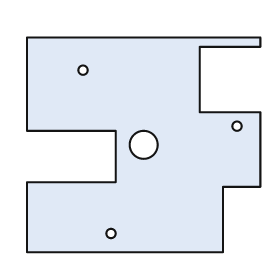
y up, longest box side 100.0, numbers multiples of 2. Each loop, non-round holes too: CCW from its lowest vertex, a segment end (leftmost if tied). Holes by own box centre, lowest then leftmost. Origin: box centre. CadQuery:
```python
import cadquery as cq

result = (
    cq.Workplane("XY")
    .moveTo(-50.0, -46.0)
    .lineTo(34.0, -46.0)
    .lineTo(34.0, -18.0)
    .lineTo(50.0, -18.0)
    .lineTo(50.0, 14.0)
    .lineTo(24.0, 14.0)
    .lineTo(24.0, 42.0)
    .lineTo(50.0, 42.0)
    .lineTo(50.0, 46.0)
    .lineTo(-50.0, 46.0)
    .lineTo(-50.0, 6.0)
    .lineTo(-12.0, 6.0)
    .lineTo(-12.0, -16.0)
    .lineTo(-50.0, -16.0)
    .close()
    .moveTo(-14.0, -38.0)
    .circle(2.0)
    .moveTo(0.0, 0.0)
    .circle(6.0)
    .moveTo(40.0, 8.0)
    .circle(2.0)
    .moveTo(-26.0, 32.0)
    .circle(2.0)
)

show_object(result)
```